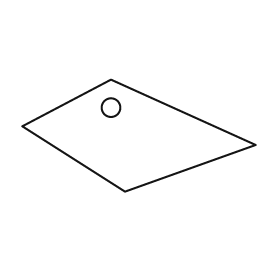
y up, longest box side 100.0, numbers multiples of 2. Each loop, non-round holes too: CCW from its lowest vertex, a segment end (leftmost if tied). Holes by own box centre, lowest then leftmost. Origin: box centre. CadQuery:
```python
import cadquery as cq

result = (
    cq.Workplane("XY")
    .moveTo(-6.0, -24.0)
    .lineTo(50.0, -4.0)
    .lineTo(-12.0, 24.0)
    .lineTo(-50.0, 4.0)
    .close()
    .moveTo(-12.0, 12.0)
    .circle(4.0)
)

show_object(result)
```